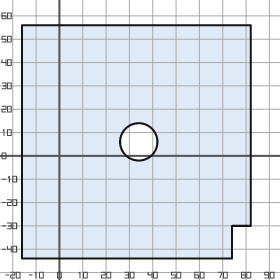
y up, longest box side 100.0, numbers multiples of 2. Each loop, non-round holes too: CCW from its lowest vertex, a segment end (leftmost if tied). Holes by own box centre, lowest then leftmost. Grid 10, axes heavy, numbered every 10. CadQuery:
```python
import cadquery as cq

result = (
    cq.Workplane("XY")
    .moveTo(-16.0, -44.0)
    .lineTo(74.0, -44.0)
    .lineTo(74.0, -30.0)
    .lineTo(82.0, -30.0)
    .lineTo(82.0, 56.0)
    .lineTo(-16.0, 56.0)
    .close()
    .moveTo(34.0, 6.0)
    .circle(8.0)
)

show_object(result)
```